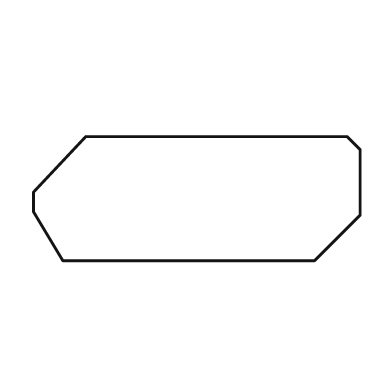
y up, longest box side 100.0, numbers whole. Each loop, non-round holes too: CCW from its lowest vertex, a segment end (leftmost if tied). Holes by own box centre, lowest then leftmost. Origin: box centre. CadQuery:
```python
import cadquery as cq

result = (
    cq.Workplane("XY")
    .moveTo(-41.0, -19.0)
    .lineTo(36.0, -19.0)
    .lineTo(50.0, -5.0)
    .lineTo(50.0, 15.0)
    .lineTo(46.0, 19.0)
    .lineTo(-34.0, 19.0)
    .lineTo(-50.0, 2.0)
    .lineTo(-50.0, -4.0)
    .close()
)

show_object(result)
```